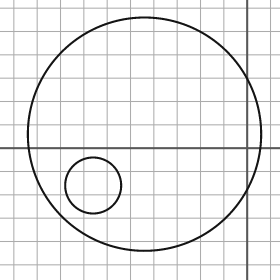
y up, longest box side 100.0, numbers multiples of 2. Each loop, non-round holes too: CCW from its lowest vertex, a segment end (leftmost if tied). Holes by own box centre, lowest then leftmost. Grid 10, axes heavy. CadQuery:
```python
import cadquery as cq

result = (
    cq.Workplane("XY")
    .moveTo(-44.0, 6.0)
    .circle(50.0)
    .moveTo(-66.0, -16.0)
    .circle(12.0)
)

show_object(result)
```